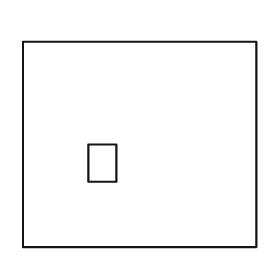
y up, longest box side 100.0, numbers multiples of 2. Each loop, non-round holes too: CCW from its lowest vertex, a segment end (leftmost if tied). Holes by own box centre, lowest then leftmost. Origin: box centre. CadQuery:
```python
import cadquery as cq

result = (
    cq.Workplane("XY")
    .moveTo(-50.0, -44.0)
    .lineTo(50.0, -44.0)
    .lineTo(50.0, 44.0)
    .lineTo(-50.0, 44.0)
    .close()
    .moveTo(-22.0, -16.0)
    .lineTo(-10.0, -16.0)
    .lineTo(-10.0, 0.0)
    .lineTo(-22.0, 0.0)
    .close()
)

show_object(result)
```